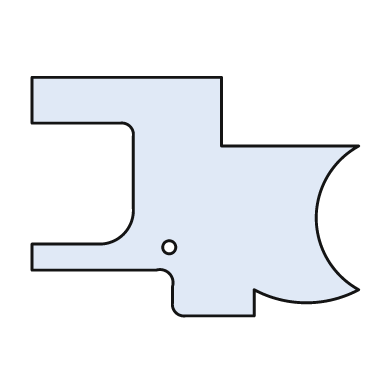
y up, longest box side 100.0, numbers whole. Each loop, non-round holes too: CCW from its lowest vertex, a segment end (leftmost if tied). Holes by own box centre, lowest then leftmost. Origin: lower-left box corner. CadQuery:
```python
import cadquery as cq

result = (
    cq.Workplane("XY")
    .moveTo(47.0, 0.0)
    .lineTo(68.0, 0.0)
    .lineTo(68.0, 8.0)
    .threePointArc((84.0, 4.0), (100.0, 8.0))
    .threePointArc((87.0, 30.0), (100.0, 52.0))
    .lineTo(58.0, 52.0)
    .lineTo(58.0, 73.0)
    .lineTo(0.0, 73.0)
    .lineTo(0.0, 59.0)
    .lineTo(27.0, 59.0)
    .threePointArc((30.0, 58.0), (31.0, 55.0))
    .lineTo(31.0, 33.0)
    .threePointArc((28.0, 25.0), (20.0, 22.0))
    .lineTo(0.0, 22.0)
    .lineTo(0.0, 14.0)
    .lineTo(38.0, 14.0)
    .threePointArc((42.0, 13.0), (43.0, 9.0))
    .lineTo(43.0, 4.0)
    .threePointArc((44.0, 1.0), (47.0, 0.0))
    .close()
    .moveTo(42.0, 21.0)
    .circle(2.0)
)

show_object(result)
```